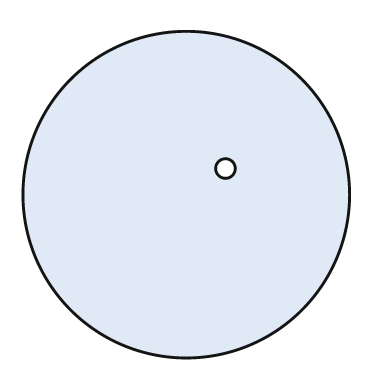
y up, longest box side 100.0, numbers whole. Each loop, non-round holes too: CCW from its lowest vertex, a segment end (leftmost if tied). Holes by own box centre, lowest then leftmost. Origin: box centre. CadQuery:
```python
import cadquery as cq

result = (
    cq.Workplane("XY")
    .moveTo(0.0, 0.0)
    .circle(50.0)
    .moveTo(12.0, 8.0)
    .circle(3.0)
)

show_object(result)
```